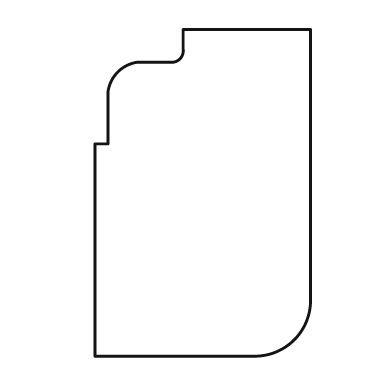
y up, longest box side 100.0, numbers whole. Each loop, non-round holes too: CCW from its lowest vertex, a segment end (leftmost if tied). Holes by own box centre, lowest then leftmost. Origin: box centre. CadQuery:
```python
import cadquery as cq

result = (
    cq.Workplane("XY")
    .moveTo(-33.0, -50.0)
    .lineTo(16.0, -50.0)
    .threePointArc((28.0, -45.0), (33.0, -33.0))
    .lineTo(33.0, 50.0)
    .lineTo(-6.0, 50.0)
    .lineTo(-6.0, 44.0)
    .threePointArc((-7.0, 41.0), (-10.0, 40.0))
    .lineTo(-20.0, 40.0)
    .threePointArc((-26.0, 37.0), (-29.0, 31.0))
    .lineTo(-29.0, 15.0)
    .lineTo(-33.0, 15.0)
    .close()
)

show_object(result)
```